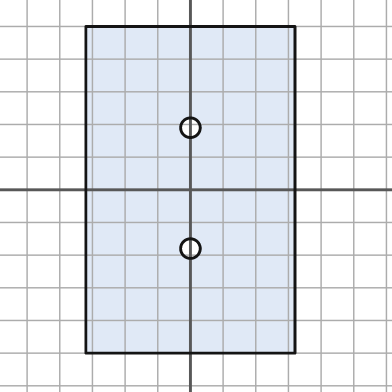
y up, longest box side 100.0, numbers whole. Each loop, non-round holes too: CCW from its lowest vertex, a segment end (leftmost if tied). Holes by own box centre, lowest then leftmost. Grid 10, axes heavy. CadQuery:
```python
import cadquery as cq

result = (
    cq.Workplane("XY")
    .moveTo(-32.0, -50.0)
    .lineTo(32.0, -50.0)
    .lineTo(32.0, 50.0)
    .lineTo(-32.0, 50.0)
    .close()
    .moveTo(0.0, -18.0)
    .circle(3.0)
    .moveTo(0.0, 19.0)
    .circle(3.0)
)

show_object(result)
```